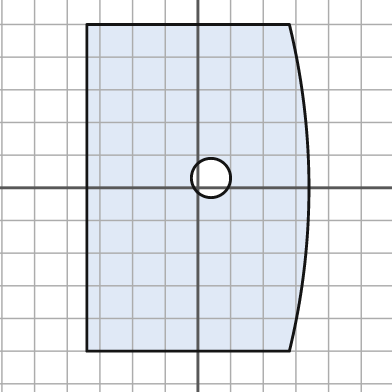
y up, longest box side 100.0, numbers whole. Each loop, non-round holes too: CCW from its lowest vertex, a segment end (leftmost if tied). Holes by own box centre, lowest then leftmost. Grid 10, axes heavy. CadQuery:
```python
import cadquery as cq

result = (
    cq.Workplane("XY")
    .moveTo(-34.0, -50.0)
    .lineTo(28.0, -50.0)
    .threePointArc((34.0, 0.0), (28.0, 50.0))
    .lineTo(-34.0, 50.0)
    .close()
    .moveTo(4.0, 3.0)
    .circle(6.0)
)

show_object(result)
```